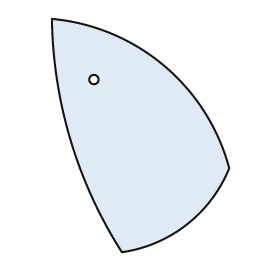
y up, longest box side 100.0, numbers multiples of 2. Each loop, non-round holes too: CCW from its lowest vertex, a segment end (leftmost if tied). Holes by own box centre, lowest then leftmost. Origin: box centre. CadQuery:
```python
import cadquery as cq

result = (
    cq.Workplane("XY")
    .moveTo(-8.0, -50.0)
    .threePointArc((20.0, -38.0), (38.0, -14.0))
    .threePointArc((10.0, 30.0), (-38.0, 50.0))
    .threePointArc((-30.0, -2.0), (-8.0, -50.0))
    .close()
    .moveTo(-20.0, 24.0)
    .circle(2.0)
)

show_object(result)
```